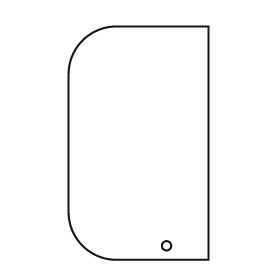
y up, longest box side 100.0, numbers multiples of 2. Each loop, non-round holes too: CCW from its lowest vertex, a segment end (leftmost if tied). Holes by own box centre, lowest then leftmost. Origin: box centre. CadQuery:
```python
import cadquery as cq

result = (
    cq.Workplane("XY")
    .moveTo(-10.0, -50.0)
    .lineTo(30.0, -50.0)
    .lineTo(30.0, 50.0)
    .lineTo(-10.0, 50.0)
    .threePointArc((-24.0, 44.0), (-30.0, 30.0))
    .lineTo(-30.0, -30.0)
    .threePointArc((-24.0, -44.0), (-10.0, -50.0))
    .close()
    .moveTo(12.0, -44.0)
    .circle(2.0)
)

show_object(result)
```